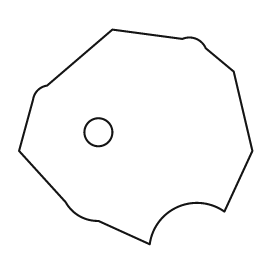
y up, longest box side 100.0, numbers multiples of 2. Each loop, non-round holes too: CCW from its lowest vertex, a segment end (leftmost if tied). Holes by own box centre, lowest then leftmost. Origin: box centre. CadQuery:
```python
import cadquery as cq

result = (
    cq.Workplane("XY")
    .moveTo(6.0, -46.0)
    .threePointArc((18.0, -30.0), (38.0, -32.0))
    .lineTo(50.0, -6.0)
    .lineTo(42.0, 28.0)
    .lineTo(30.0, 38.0)
    .threePointArc((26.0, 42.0), (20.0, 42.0))
    .lineTo(-10.0, 46.0)
    .lineTo(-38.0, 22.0)
    .threePointArc((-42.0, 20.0), (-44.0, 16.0))
    .lineTo(-50.0, -6.0)
    .lineTo(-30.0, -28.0)
    .threePointArc((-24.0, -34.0), (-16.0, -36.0))
    .close()
    .moveTo(-16.0, 2.0)
    .circle(6.0)
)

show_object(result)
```